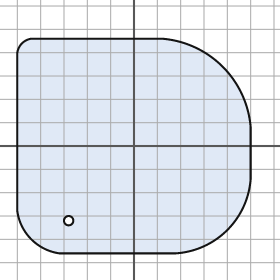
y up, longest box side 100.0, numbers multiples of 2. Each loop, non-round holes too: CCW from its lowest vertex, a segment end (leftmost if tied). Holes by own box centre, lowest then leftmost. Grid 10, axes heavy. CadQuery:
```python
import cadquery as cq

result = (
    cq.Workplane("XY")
    .moveTo(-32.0, -46.0)
    .lineTo(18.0, -46.0)
    .threePointArc((40.0, -36.0), (50.0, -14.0))
    .lineTo(50.0, 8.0)
    .threePointArc((38.0, 34.0), (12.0, 46.0))
    .lineTo(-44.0, 46.0)
    .threePointArc((-48.0, 44.0), (-50.0, 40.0))
    .lineTo(-50.0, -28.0)
    .threePointArc((-44.0, -40.0), (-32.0, -46.0))
    .close()
    .moveTo(-28.0, -32.0)
    .circle(2.0)
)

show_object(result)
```